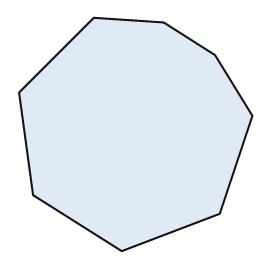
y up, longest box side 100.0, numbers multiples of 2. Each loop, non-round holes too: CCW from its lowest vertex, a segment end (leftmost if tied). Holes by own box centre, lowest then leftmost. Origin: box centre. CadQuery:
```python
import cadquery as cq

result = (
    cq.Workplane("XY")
    .moveTo(-6.0, -50.0)
    .lineTo(36.0, -34.0)
    .lineTo(50.0, 8.0)
    .lineTo(34.0, 34.0)
    .lineTo(12.0, 48.0)
    .lineTo(-18.0, 50.0)
    .lineTo(-50.0, 18.0)
    .lineTo(-44.0, -26.0)
    .close()
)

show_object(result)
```